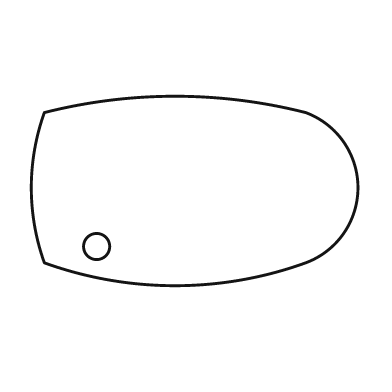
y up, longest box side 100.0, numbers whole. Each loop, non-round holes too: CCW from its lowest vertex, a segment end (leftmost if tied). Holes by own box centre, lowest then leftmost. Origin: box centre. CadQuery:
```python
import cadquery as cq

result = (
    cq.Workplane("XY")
    .moveTo(-46.0, -22.0)
    .threePointArc((-6.0, -29.0), (34.0, -22.0))
    .threePointArc((50.0, 1.0), (34.0, 24.0))
    .threePointArc((-6.0, 29.0), (-46.0, 24.0))
    .threePointArc((-50.0, 1.0), (-46.0, -22.0))
    .close()
    .moveTo(-30.0, -17.0)
    .circle(4.0)
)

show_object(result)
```